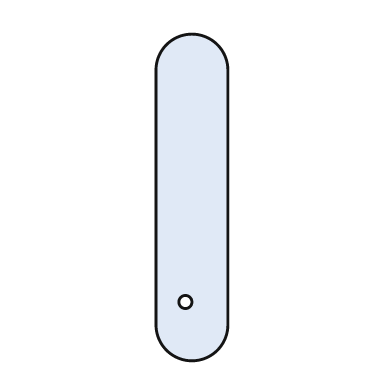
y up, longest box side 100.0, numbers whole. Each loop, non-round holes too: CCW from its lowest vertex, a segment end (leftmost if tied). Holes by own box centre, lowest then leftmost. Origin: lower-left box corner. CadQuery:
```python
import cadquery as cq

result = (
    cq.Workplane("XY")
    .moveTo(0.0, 11.0)
    .threePointArc((11.0, 0.0), (22.0, 11.0))
    .lineTo(22.0, 89.0)
    .threePointArc((11.0, 100.0), (0.0, 89.0))
    .close()
    .moveTo(9.0, 18.0)
    .circle(2.0)
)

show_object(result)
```